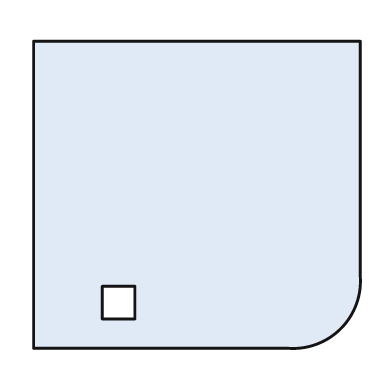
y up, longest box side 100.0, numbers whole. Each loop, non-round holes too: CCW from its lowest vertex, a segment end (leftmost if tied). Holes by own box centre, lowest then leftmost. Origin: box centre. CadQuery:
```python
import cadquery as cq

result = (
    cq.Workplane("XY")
    .moveTo(-50.0, -47.0)
    .lineTo(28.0, -47.0)
    .threePointArc((44.0, -41.0), (50.0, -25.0))
    .lineTo(50.0, 47.0)
    .lineTo(-50.0, 47.0)
    .close()
    .moveTo(-29.0, -38.0)
    .lineTo(-19.0, -38.0)
    .lineTo(-19.0, -28.0)
    .lineTo(-29.0, -28.0)
    .close()
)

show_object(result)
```